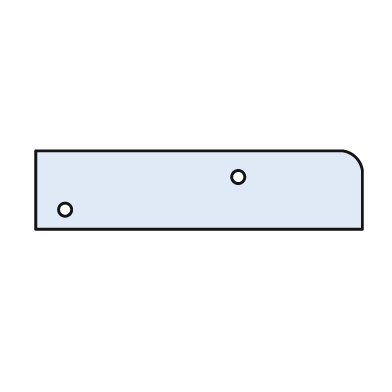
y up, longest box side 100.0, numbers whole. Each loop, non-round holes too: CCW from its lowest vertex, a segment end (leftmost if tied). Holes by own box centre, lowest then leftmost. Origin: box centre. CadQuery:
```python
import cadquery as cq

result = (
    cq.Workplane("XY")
    .moveTo(-50.0, -12.0)
    .lineTo(50.0, -12.0)
    .lineTo(50.0, 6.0)
    .threePointArc((48.0, 10.0), (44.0, 12.0))
    .lineTo(-50.0, 12.0)
    .close()
    .moveTo(-41.0, -6.0)
    .circle(2.0)
    .moveTo(12.0, 4.0)
    .circle(2.0)
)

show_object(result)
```